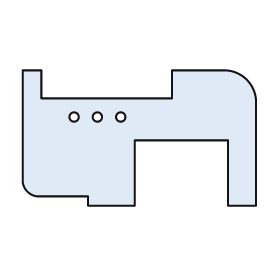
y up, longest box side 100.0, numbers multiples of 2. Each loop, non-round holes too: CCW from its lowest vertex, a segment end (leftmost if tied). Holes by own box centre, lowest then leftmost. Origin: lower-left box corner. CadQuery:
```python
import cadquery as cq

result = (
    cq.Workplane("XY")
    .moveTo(28.0, 0.0)
    .lineTo(48.0, 0.0)
    .lineTo(48.0, 28.0)
    .lineTo(88.0, 28.0)
    .lineTo(88.0, 0.0)
    .lineTo(100.0, 0.0)
    .lineTo(100.0, 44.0)
    .threePointArc((96.0, 54.0), (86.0, 58.0))
    .lineTo(64.0, 58.0)
    .lineTo(64.0, 46.0)
    .lineTo(8.0, 46.0)
    .lineTo(8.0, 58.0)
    .lineTo(0.0, 58.0)
    .lineTo(0.0, 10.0)
    .threePointArc((2.0, 6.0), (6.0, 4.0))
    .lineTo(28.0, 4.0)
    .close()
    .moveTo(22.0, 38.0)
    .circle(2.0)
    .moveTo(32.0, 38.0)
    .circle(2.0)
    .moveTo(42.0, 38.0)
    .circle(2.0)
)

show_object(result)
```